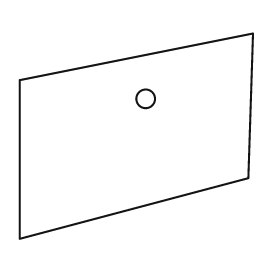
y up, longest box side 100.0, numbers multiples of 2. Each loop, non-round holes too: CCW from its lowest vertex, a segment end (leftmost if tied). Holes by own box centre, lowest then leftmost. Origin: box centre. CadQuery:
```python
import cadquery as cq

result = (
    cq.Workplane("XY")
    .moveTo(-50.0, -44.0)
    .lineTo(48.0, -18.0)
    .lineTo(50.0, 44.0)
    .lineTo(-50.0, 24.0)
    .close()
    .moveTo(4.0, 16.0)
    .circle(4.0)
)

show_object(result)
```